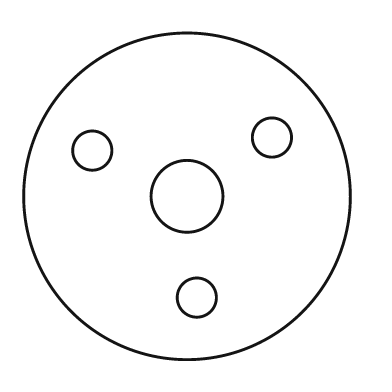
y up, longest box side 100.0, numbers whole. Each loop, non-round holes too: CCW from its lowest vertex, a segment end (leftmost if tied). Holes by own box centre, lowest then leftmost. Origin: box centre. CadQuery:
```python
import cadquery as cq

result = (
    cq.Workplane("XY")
    .moveTo(0.0, 0.0)
    .circle(50.0)
    .moveTo(3.0, -31.0)
    .circle(6.0)
    .moveTo(0.0, 0.0)
    .circle(11.0)
    .moveTo(-29.0, 14.0)
    .circle(6.0)
    .moveTo(26.0, 18.0)
    .circle(6.0)
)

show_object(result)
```